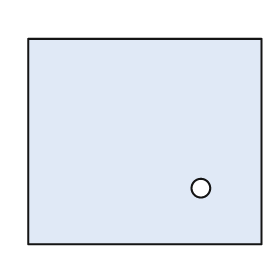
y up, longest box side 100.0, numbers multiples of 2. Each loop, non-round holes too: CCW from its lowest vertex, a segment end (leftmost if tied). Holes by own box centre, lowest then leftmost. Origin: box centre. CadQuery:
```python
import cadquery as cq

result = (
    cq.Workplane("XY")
    .moveTo(-50.0, -44.0)
    .lineTo(50.0, -44.0)
    .lineTo(50.0, 44.0)
    .lineTo(-50.0, 44.0)
    .close()
    .moveTo(24.0, -20.0)
    .circle(4.0)
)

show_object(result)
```